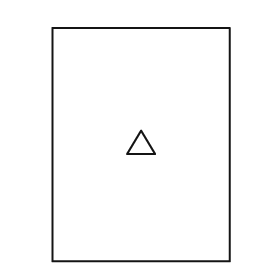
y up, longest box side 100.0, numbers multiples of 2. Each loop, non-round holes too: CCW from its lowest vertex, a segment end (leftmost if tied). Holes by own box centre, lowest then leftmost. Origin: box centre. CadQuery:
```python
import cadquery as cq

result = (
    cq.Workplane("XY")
    .moveTo(-38.0, -50.0)
    .lineTo(38.0, -50.0)
    .lineTo(38.0, 50.0)
    .lineTo(-38.0, 50.0)
    .close()
    .moveTo(-6.0, -4.0)
    .lineTo(6.0, -4.0)
    .lineTo(0.0, 6.0)
    .close()
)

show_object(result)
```